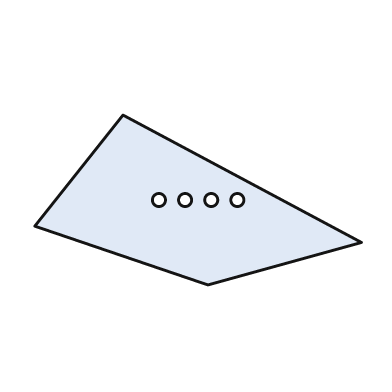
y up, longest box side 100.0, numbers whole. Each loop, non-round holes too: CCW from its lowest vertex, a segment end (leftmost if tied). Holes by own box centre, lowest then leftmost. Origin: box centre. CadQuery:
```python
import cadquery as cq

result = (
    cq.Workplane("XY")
    .moveTo(3.0, -26.0)
    .lineTo(50.0, -13.0)
    .lineTo(-23.0, 26.0)
    .lineTo(-50.0, -8.0)
    .close()
    .moveTo(-12.0, 0.0)
    .circle(2.0)
    .moveTo(-4.0, 0.0)
    .circle(2.0)
    .moveTo(4.0, 0.0)
    .circle(2.0)
    .moveTo(12.0, 0.0)
    .circle(2.0)
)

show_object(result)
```